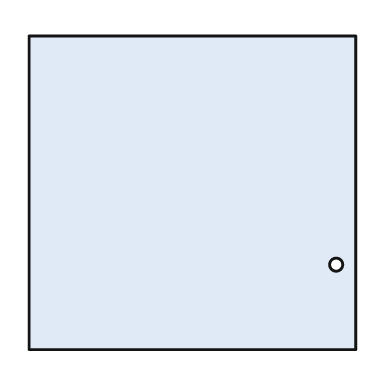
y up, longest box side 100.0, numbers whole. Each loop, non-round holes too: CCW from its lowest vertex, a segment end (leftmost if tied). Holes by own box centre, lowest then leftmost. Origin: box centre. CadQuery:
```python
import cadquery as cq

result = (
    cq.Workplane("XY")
    .moveTo(-50.0, -48.0)
    .lineTo(50.0, -48.0)
    .lineTo(50.0, 48.0)
    .lineTo(-50.0, 48.0)
    .close()
    .moveTo(44.0, -22.0)
    .circle(2.0)
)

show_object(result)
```